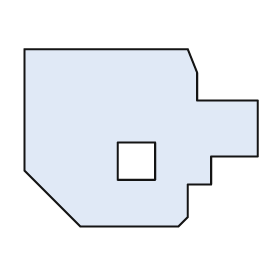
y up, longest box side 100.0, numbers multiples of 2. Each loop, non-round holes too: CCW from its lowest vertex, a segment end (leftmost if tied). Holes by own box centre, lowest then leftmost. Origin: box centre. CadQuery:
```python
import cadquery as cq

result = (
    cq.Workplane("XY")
    .moveTo(-26.0, -38.0)
    .lineTo(16.0, -38.0)
    .lineTo(20.0, -34.0)
    .lineTo(20.0, -20.0)
    .lineTo(30.0, -20.0)
    .lineTo(30.0, -8.0)
    .lineTo(50.0, -8.0)
    .lineTo(50.0, 16.0)
    .lineTo(24.0, 16.0)
    .lineTo(24.0, 28.0)
    .lineTo(20.0, 38.0)
    .lineTo(-50.0, 38.0)
    .lineTo(-50.0, -14.0)
    .close()
    .moveTo(-10.0, -18.0)
    .lineTo(6.0, -18.0)
    .lineTo(6.0, -2.0)
    .lineTo(-10.0, -2.0)
    .close()
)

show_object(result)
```